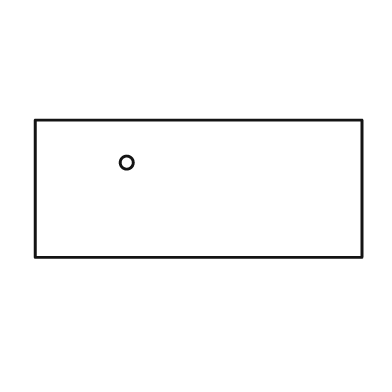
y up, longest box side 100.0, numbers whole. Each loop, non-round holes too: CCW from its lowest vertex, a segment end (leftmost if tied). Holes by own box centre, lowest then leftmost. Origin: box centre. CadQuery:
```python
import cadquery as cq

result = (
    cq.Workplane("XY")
    .moveTo(-50.0, -21.0)
    .lineTo(50.0, -21.0)
    .lineTo(50.0, 21.0)
    .lineTo(-50.0, 21.0)
    .close()
    .moveTo(-22.0, 8.0)
    .circle(2.0)
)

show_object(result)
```